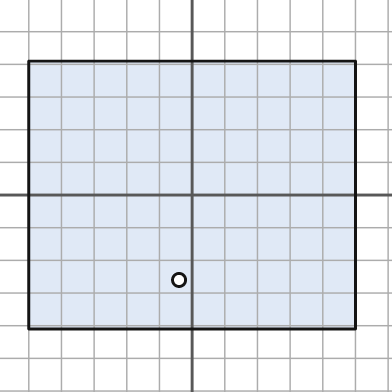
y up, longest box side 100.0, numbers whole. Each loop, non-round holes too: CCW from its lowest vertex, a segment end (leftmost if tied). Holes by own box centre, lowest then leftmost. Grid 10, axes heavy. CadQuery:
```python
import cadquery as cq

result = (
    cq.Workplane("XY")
    .moveTo(-50.0, -41.0)
    .lineTo(50.0, -41.0)
    .lineTo(50.0, 41.0)
    .lineTo(-50.0, 41.0)
    .close()
    .moveTo(-4.0, -26.0)
    .circle(2.0)
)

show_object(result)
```